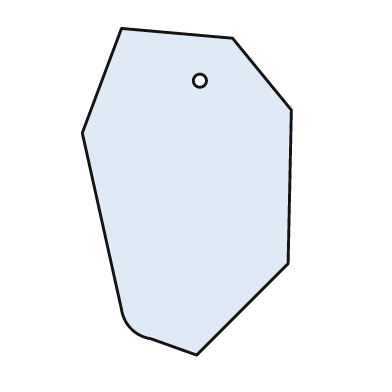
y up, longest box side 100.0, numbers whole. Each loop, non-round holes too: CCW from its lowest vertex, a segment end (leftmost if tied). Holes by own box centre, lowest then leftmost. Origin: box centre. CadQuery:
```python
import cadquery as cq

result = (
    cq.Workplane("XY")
    .moveTo(3.0, -50.0)
    .lineTo(31.0, -22.0)
    .lineTo(32.0, 25.0)
    .lineTo(14.0, 47.0)
    .lineTo(-20.0, 50.0)
    .lineTo(-32.0, 18.0)
    .lineTo(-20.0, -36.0)
    .threePointArc((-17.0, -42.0), (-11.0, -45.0))
    .close()
    .moveTo(4.0, 34.0)
    .circle(2.0)
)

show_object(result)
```